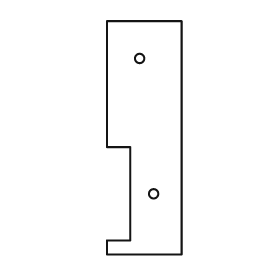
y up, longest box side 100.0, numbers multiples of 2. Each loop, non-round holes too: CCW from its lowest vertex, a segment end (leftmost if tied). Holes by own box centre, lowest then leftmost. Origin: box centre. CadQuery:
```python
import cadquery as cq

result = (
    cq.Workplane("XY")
    .moveTo(-16.0, -50.0)
    .lineTo(16.0, -50.0)
    .lineTo(16.0, 50.0)
    .lineTo(-16.0, 50.0)
    .lineTo(-16.0, -4.0)
    .lineTo(-6.0, -4.0)
    .lineTo(-6.0, -44.0)
    .lineTo(-16.0, -44.0)
    .close()
    .moveTo(4.0, -24.0)
    .circle(2.0)
    .moveTo(-2.0, 34.0)
    .circle(2.0)
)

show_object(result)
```